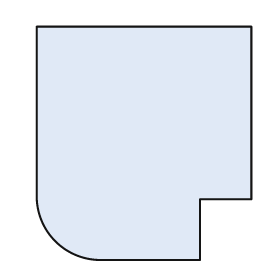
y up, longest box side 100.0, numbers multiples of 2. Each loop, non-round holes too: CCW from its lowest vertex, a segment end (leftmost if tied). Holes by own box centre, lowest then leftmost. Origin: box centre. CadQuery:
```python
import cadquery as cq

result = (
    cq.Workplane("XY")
    .moveTo(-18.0, -50.0)
    .lineTo(24.0, -50.0)
    .lineTo(24.0, -24.0)
    .lineTo(46.0, -24.0)
    .lineTo(46.0, 50.0)
    .lineTo(-46.0, 50.0)
    .lineTo(-46.0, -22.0)
    .threePointArc((-38.0, -42.0), (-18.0, -50.0))
    .close()
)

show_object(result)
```